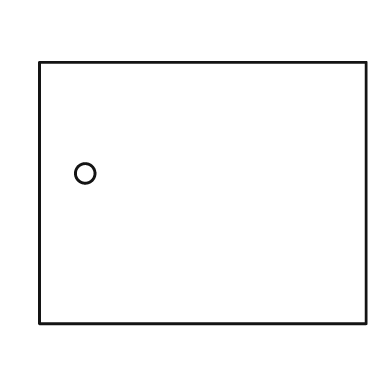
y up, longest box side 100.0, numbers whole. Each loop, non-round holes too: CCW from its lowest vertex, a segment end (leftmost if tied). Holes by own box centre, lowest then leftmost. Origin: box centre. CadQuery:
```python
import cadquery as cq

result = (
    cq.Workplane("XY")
    .moveTo(-50.0, -40.0)
    .lineTo(50.0, -40.0)
    .lineTo(50.0, 40.0)
    .lineTo(-50.0, 40.0)
    .close()
    .moveTo(-36.0, 6.0)
    .circle(3.0)
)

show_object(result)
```